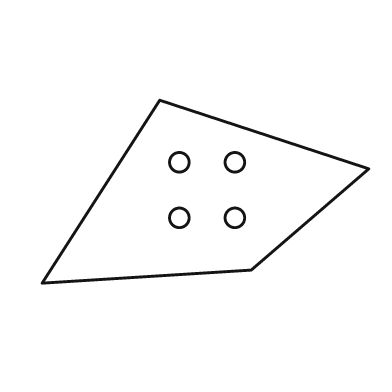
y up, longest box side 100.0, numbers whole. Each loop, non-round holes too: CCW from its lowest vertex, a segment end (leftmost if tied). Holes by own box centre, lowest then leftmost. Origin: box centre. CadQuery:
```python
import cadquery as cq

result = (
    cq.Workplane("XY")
    .moveTo(-50.0, -28.0)
    .lineTo(14.0, -24.0)
    .lineTo(50.0, 7.0)
    .lineTo(-14.0, 28.0)
    .close()
    .moveTo(-8.0, -8.0)
    .circle(3.0)
    .moveTo(9.0, -8.0)
    .circle(3.0)
    .moveTo(-8.0, 9.0)
    .circle(3.0)
    .moveTo(9.0, 9.0)
    .circle(3.0)
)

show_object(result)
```